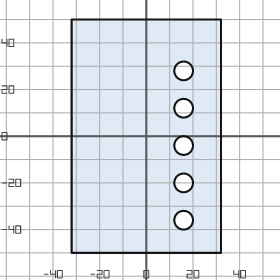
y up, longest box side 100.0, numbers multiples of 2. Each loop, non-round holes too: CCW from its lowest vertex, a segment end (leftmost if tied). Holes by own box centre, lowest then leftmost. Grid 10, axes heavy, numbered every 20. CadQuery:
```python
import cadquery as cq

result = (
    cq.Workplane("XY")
    .moveTo(-32.0, -50.0)
    .lineTo(32.0, -50.0)
    .lineTo(32.0, 50.0)
    .lineTo(-32.0, 50.0)
    .close()
    .moveTo(16.0, -36.0)
    .circle(4.0)
    .moveTo(16.0, -20.0)
    .circle(4.0)
    .moveTo(16.0, -4.0)
    .circle(4.0)
    .moveTo(16.0, 12.0)
    .circle(4.0)
    .moveTo(16.0, 28.0)
    .circle(4.0)
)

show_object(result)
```